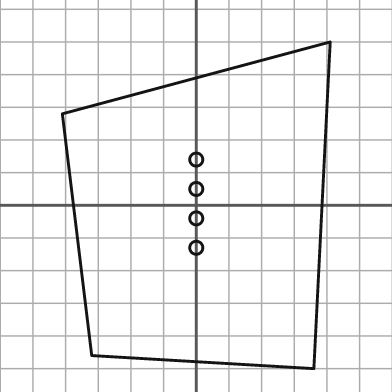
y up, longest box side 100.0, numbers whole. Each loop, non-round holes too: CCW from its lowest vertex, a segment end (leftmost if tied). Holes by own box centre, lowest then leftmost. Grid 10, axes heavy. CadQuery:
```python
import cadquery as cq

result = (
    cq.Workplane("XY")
    .moveTo(36.0, -50.0)
    .lineTo(41.0, 50.0)
    .lineTo(-41.0, 28.0)
    .lineTo(-32.0, -46.0)
    .close()
    .moveTo(0.0, -13.0)
    .circle(2.0)
    .moveTo(0.0, -4.0)
    .circle(2.0)
    .moveTo(0.0, 5.0)
    .circle(2.0)
    .moveTo(0.0, 14.0)
    .circle(2.0)
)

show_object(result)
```